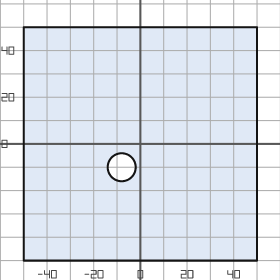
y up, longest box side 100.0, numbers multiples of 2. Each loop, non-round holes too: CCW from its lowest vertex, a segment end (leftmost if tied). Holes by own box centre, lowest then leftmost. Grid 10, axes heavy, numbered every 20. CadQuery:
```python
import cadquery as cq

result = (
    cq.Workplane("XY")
    .moveTo(-50.0, -50.0)
    .lineTo(50.0, -50.0)
    .lineTo(50.0, 50.0)
    .lineTo(-50.0, 50.0)
    .close()
    .moveTo(-8.0, -10.0)
    .circle(6.0)
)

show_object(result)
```